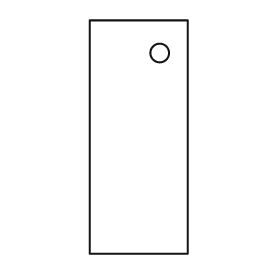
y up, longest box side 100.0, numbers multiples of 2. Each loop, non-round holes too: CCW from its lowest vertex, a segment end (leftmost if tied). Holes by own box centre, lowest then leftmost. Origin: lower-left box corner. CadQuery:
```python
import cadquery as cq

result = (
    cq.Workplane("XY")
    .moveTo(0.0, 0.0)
    .lineTo(42.0, 0.0)
    .lineTo(42.0, 100.0)
    .lineTo(0.0, 100.0)
    .close()
    .moveTo(30.0, 86.0)
    .circle(4.0)
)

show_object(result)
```